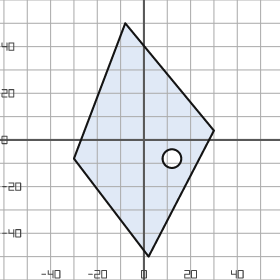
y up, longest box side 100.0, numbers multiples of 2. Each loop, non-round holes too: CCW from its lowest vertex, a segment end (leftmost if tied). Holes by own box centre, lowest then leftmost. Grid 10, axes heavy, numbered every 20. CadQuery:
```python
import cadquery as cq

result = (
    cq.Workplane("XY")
    .moveTo(2.0, -50.0)
    .lineTo(30.0, 4.0)
    .lineTo(-8.0, 50.0)
    .lineTo(-30.0, -8.0)
    .close()
    .moveTo(12.0, -8.0)
    .circle(4.0)
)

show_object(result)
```